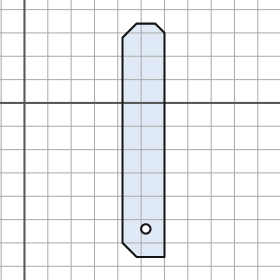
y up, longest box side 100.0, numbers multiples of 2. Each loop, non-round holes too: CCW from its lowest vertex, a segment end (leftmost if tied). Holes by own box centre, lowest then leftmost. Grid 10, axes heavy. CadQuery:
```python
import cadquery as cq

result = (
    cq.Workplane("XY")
    .moveTo(48.0, -66.0)
    .lineTo(60.0, -66.0)
    .lineTo(60.0, 30.0)
    .lineTo(56.0, 34.0)
    .lineTo(48.0, 34.0)
    .lineTo(42.0, 28.0)
    .lineTo(42.0, -60.0)
    .close()
    .moveTo(52.0, -54.0)
    .circle(2.0)
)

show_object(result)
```